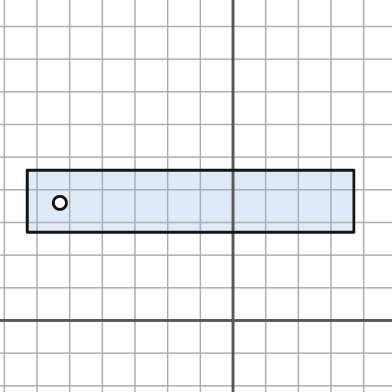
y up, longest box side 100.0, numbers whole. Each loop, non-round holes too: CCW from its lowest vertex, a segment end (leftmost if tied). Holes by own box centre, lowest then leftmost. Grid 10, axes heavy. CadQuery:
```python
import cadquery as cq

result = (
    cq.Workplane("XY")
    .moveTo(-63.0, 27.0)
    .lineTo(37.0, 27.0)
    .lineTo(37.0, 46.0)
    .lineTo(-63.0, 46.0)
    .close()
    .moveTo(-53.0, 36.0)
    .circle(2.0)
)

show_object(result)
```